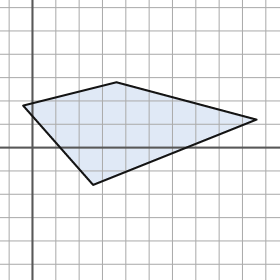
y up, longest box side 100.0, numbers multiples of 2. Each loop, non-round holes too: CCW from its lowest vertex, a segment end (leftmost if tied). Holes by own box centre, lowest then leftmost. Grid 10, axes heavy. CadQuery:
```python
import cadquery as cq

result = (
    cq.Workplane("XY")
    .moveTo(26.0, -16.0)
    .lineTo(96.0, 12.0)
    .lineTo(36.0, 28.0)
    .lineTo(-4.0, 18.0)
    .close()
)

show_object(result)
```